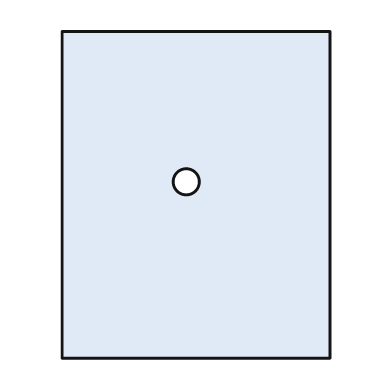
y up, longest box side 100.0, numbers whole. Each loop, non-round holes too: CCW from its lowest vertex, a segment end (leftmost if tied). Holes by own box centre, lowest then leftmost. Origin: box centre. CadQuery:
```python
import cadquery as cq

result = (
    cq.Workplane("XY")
    .moveTo(-41.0, -50.0)
    .lineTo(41.0, -50.0)
    .lineTo(41.0, 50.0)
    .lineTo(-41.0, 50.0)
    .close()
    .moveTo(-3.0, 4.0)
    .circle(4.0)
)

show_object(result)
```